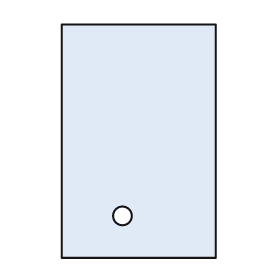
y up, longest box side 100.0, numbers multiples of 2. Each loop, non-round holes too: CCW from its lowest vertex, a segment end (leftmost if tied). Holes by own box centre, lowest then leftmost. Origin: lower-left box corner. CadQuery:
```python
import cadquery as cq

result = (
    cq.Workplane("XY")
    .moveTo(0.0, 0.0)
    .lineTo(66.0, 0.0)
    .lineTo(66.0, 100.0)
    .lineTo(0.0, 100.0)
    .close()
    .moveTo(26.0, 18.0)
    .circle(4.0)
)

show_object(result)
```